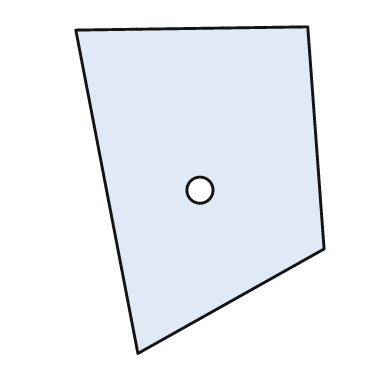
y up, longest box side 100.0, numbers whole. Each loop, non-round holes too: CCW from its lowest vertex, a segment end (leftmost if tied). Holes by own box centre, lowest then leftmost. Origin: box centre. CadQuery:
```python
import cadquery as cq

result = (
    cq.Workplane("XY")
    .moveTo(-19.0, -50.0)
    .lineTo(38.0, -18.0)
    .lineTo(33.0, 50.0)
    .lineTo(-38.0, 49.0)
    .close()
    .moveTo(0.0, 0.0)
    .circle(4.0)
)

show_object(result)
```